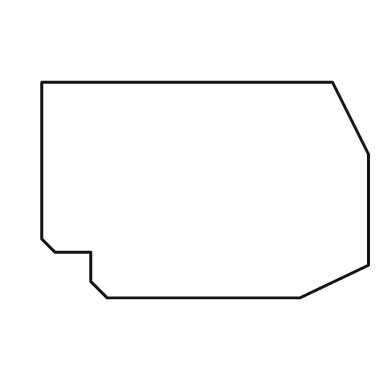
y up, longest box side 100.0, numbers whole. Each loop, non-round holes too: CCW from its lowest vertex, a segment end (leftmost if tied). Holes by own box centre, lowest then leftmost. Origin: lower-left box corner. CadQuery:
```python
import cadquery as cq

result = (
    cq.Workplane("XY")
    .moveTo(20.0, 0.0)
    .lineTo(79.0, 0.0)
    .lineTo(100.0, 10.0)
    .lineTo(100.0, 44.0)
    .lineTo(89.0, 66.0)
    .lineTo(0.0, 66.0)
    .lineTo(0.0, 18.0)
    .lineTo(4.0, 14.0)
    .lineTo(15.0, 14.0)
    .lineTo(15.0, 5.0)
    .close()
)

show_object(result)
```